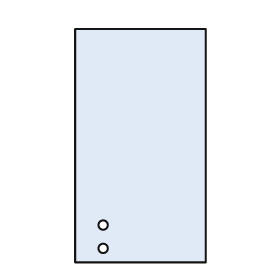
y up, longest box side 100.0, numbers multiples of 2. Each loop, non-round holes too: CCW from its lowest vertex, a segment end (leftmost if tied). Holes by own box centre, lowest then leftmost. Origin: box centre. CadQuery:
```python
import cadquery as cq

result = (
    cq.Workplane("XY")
    .moveTo(-28.0, -50.0)
    .lineTo(28.0, -50.0)
    .lineTo(28.0, 50.0)
    .lineTo(-28.0, 50.0)
    .close()
    .moveTo(-16.0, -44.0)
    .circle(2.0)
    .moveTo(-16.0, -34.0)
    .circle(2.0)
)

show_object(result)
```